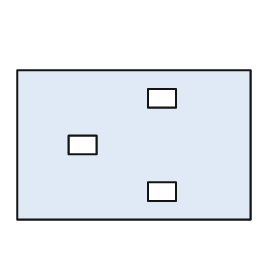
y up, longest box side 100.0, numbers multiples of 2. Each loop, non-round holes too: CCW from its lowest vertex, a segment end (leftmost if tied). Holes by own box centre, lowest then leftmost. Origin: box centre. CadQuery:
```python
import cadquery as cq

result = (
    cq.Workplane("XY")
    .moveTo(-50.0, -32.0)
    .lineTo(50.0, -32.0)
    .lineTo(50.0, 32.0)
    .lineTo(-50.0, 32.0)
    .close()
    .moveTo(6.0, -24.0)
    .lineTo(18.0, -24.0)
    .lineTo(18.0, -16.0)
    .lineTo(6.0, -16.0)
    .close()
    .moveTo(-28.0, -4.0)
    .lineTo(-16.0, -4.0)
    .lineTo(-16.0, 4.0)
    .lineTo(-28.0, 4.0)
    .close()
    .moveTo(6.0, 16.0)
    .lineTo(18.0, 16.0)
    .lineTo(18.0, 24.0)
    .lineTo(6.0, 24.0)
    .close()
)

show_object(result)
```